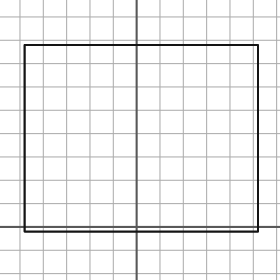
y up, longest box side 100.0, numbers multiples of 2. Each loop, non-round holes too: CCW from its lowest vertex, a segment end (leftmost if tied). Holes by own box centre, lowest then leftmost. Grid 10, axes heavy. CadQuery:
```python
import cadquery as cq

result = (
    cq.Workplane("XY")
    .moveTo(-48.0, -2.0)
    .lineTo(52.0, -2.0)
    .lineTo(52.0, 78.0)
    .lineTo(-48.0, 78.0)
    .close()
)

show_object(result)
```